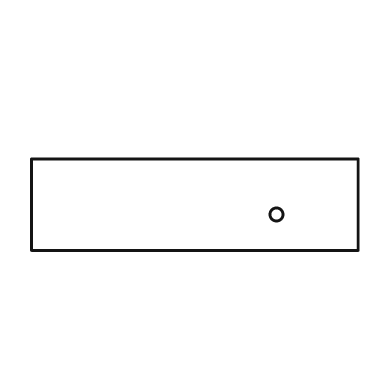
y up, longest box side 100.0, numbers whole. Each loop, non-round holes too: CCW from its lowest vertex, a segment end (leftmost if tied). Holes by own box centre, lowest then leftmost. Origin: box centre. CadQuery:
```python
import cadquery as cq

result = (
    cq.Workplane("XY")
    .moveTo(-50.0, -14.0)
    .lineTo(50.0, -14.0)
    .lineTo(50.0, 14.0)
    .lineTo(-50.0, 14.0)
    .close()
    .moveTo(25.0, -3.0)
    .circle(2.0)
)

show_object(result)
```